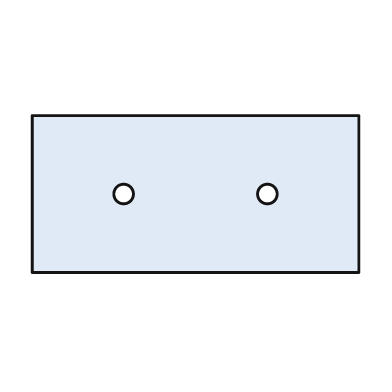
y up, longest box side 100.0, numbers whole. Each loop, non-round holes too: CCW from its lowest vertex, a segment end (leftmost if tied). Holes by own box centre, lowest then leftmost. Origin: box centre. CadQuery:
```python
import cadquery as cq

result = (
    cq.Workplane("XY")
    .moveTo(-50.0, -24.0)
    .lineTo(50.0, -24.0)
    .lineTo(50.0, 24.0)
    .lineTo(-50.0, 24.0)
    .close()
    .moveTo(-22.0, 0.0)
    .circle(3.0)
    .moveTo(22.0, 0.0)
    .circle(3.0)
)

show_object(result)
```